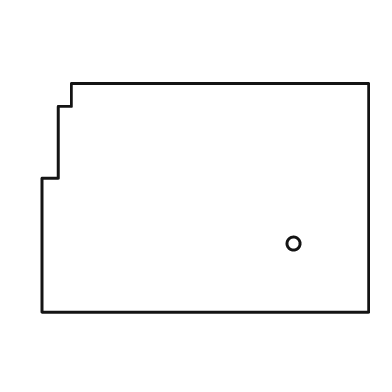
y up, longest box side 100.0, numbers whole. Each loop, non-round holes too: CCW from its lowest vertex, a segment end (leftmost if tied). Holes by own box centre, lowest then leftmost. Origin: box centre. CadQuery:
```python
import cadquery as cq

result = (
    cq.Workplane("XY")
    .moveTo(-50.0, -35.0)
    .lineTo(50.0, -35.0)
    .lineTo(50.0, 35.0)
    .lineTo(-41.0, 35.0)
    .lineTo(-41.0, 28.0)
    .lineTo(-45.0, 28.0)
    .lineTo(-45.0, 6.0)
    .lineTo(-50.0, 6.0)
    .close()
    .moveTo(27.0, -14.0)
    .circle(2.0)
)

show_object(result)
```